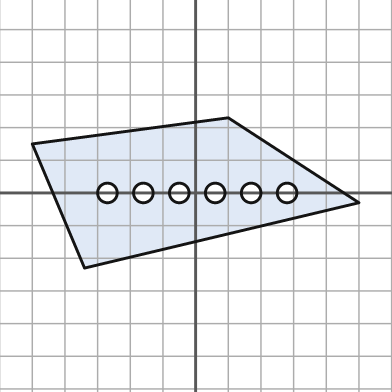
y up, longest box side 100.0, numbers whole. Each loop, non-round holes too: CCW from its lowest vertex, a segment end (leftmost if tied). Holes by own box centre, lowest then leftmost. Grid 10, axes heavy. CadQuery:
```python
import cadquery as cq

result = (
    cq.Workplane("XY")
    .moveTo(-34.0, -23.0)
    .lineTo(50.0, -3.0)
    .lineTo(10.0, 23.0)
    .lineTo(-50.0, 15.0)
    .close()
    .moveTo(-27.0, 0.0)
    .circle(3.0)
    .moveTo(-16.0, 0.0)
    .circle(3.0)
    .moveTo(-5.0, 0.0)
    .circle(3.0)
    .moveTo(6.0, 0.0)
    .circle(3.0)
    .moveTo(17.0, 0.0)
    .circle(3.0)
    .moveTo(28.0, 0.0)
    .circle(3.0)
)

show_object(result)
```